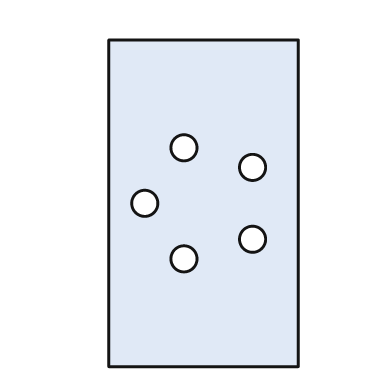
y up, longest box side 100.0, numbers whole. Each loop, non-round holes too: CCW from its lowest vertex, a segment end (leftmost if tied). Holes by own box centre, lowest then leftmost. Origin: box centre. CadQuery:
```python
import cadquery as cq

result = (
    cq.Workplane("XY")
    .moveTo(-29.0, -50.0)
    .lineTo(29.0, -50.0)
    .lineTo(29.0, 50.0)
    .lineTo(-29.0, 50.0)
    .close()
    .moveTo(-6.0, -17.0)
    .circle(4.0)
    .moveTo(15.0, -11.0)
    .circle(4.0)
    .moveTo(-18.0, 0.0)
    .circle(4.0)
    .moveTo(15.0, 11.0)
    .circle(4.0)
    .moveTo(-6.0, 17.0)
    .circle(4.0)
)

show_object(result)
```